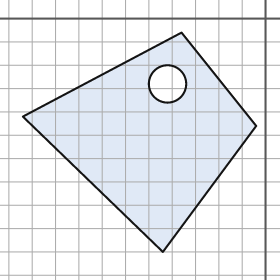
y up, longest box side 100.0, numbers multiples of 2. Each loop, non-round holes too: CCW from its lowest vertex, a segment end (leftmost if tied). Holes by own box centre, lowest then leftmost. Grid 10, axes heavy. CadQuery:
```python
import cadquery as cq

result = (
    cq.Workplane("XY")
    .moveTo(-44.0, -100.0)
    .lineTo(-4.0, -46.0)
    .lineTo(-36.0, -6.0)
    .lineTo(-104.0, -42.0)
    .close()
    .moveTo(-42.0, -28.0)
    .circle(8.0)
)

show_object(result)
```